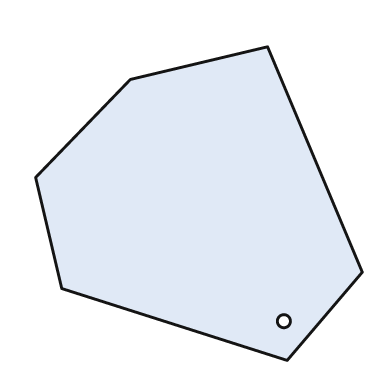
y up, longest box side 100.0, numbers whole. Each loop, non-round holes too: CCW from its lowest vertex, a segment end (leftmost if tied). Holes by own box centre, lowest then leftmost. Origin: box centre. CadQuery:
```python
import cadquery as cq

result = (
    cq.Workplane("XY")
    .moveTo(27.0, -48.0)
    .lineTo(50.0, -21.0)
    .lineTo(21.0, 48.0)
    .lineTo(-21.0, 38.0)
    .lineTo(-50.0, 8.0)
    .lineTo(-42.0, -26.0)
    .close()
    .moveTo(26.0, -36.0)
    .circle(2.0)
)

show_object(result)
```